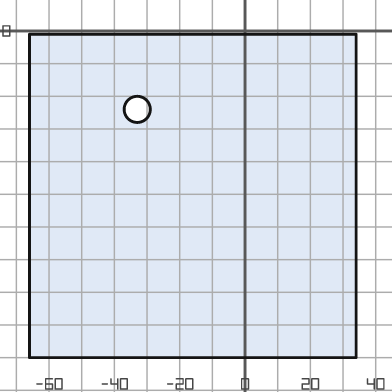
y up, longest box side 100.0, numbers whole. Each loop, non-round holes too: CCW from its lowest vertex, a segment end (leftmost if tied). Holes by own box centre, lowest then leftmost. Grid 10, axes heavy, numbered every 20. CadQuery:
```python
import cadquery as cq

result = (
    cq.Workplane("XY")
    .moveTo(-66.0, -100.0)
    .lineTo(34.0, -100.0)
    .lineTo(34.0, -1.0)
    .lineTo(-66.0, -1.0)
    .close()
    .moveTo(-33.0, -24.0)
    .circle(4.0)
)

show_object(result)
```